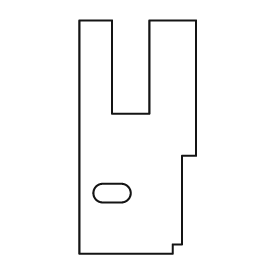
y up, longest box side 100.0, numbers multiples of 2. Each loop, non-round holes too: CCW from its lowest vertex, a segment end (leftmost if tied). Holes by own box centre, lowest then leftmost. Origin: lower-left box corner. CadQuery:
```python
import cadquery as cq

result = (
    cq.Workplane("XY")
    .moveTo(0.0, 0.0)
    .lineTo(40.0, 0.0)
    .lineTo(40.0, 4.0)
    .lineTo(44.0, 4.0)
    .lineTo(44.0, 42.0)
    .lineTo(50.0, 42.0)
    .lineTo(50.0, 100.0)
    .lineTo(30.0, 100.0)
    .lineTo(30.0, 60.0)
    .lineTo(14.0, 60.0)
    .lineTo(14.0, 100.0)
    .lineTo(0.0, 100.0)
    .close()
    .moveTo(10.0, 22.0)
    .lineTo(18.0, 22.0)
    .threePointArc((22.0, 26.0), (18.0, 30.0))
    .lineTo(10.0, 30.0)
    .threePointArc((6.0, 26.0), (10.0, 22.0))
    .close()
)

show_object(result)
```